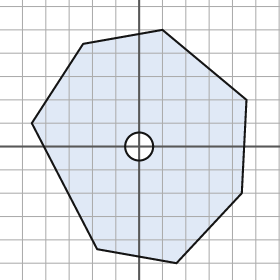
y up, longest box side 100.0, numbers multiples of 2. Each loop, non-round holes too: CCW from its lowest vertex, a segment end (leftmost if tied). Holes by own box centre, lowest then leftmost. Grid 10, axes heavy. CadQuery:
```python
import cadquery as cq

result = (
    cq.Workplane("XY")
    .moveTo(16.0, -50.0)
    .lineTo(44.0, -20.0)
    .lineTo(46.0, 20.0)
    .lineTo(10.0, 50.0)
    .lineTo(-24.0, 44.0)
    .lineTo(-46.0, 10.0)
    .lineTo(-18.0, -44.0)
    .close()
    .moveTo(0.0, 0.0)
    .circle(6.0)
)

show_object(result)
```